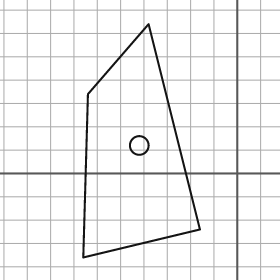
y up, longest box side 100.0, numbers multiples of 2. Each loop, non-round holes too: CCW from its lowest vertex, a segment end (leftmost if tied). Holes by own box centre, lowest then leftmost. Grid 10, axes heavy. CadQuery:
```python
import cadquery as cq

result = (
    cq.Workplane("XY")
    .moveTo(-66.0, -36.0)
    .lineTo(-16.0, -24.0)
    .lineTo(-38.0, 64.0)
    .lineTo(-64.0, 34.0)
    .close()
    .moveTo(-42.0, 12.0)
    .circle(4.0)
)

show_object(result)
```